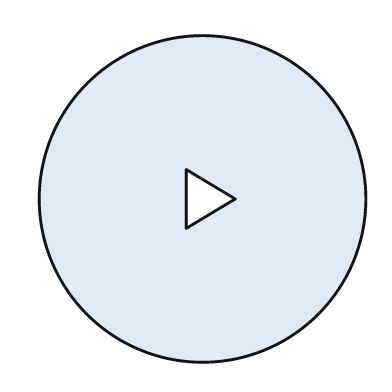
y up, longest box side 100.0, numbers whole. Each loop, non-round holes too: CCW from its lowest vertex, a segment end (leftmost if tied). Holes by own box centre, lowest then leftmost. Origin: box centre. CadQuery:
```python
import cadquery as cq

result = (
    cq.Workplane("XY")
    .moveTo(0.0, 0.0)
    .circle(50.0)
    .moveTo(-5.0, -9.0)
    .lineTo(10.0, 0.0)
    .lineTo(-5.0, 9.0)
    .close()
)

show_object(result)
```